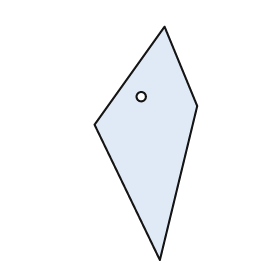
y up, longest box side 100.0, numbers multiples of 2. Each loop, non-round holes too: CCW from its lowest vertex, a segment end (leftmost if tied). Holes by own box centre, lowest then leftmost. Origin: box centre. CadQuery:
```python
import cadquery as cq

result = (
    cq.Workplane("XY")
    .moveTo(6.0, -50.0)
    .lineTo(22.0, 16.0)
    .lineTo(8.0, 50.0)
    .lineTo(-22.0, 8.0)
    .close()
    .moveTo(-2.0, 20.0)
    .circle(2.0)
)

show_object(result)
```